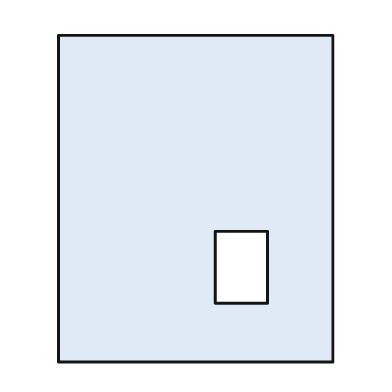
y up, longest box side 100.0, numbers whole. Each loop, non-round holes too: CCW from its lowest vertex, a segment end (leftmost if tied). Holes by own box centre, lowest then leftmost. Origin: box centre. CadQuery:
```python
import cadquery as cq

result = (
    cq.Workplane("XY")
    .moveTo(-42.0, -50.0)
    .lineTo(42.0, -50.0)
    .lineTo(42.0, 50.0)
    .lineTo(-42.0, 50.0)
    .close()
    .moveTo(6.0, -32.0)
    .lineTo(22.0, -32.0)
    .lineTo(22.0, -10.0)
    .lineTo(6.0, -10.0)
    .close()
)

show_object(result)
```